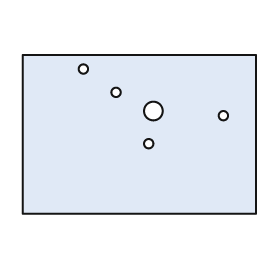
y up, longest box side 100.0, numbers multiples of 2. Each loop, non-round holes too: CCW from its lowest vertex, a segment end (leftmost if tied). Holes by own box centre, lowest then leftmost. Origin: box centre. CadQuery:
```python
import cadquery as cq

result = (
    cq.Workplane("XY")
    .moveTo(-50.0, -34.0)
    .lineTo(50.0, -34.0)
    .lineTo(50.0, 34.0)
    .lineTo(-50.0, 34.0)
    .close()
    .moveTo(4.0, -4.0)
    .circle(2.0)
    .moveTo(36.0, 8.0)
    .circle(2.0)
    .moveTo(6.0, 10.0)
    .circle(4.0)
    .moveTo(-10.0, 18.0)
    .circle(2.0)
    .moveTo(-24.0, 28.0)
    .circle(2.0)
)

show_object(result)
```